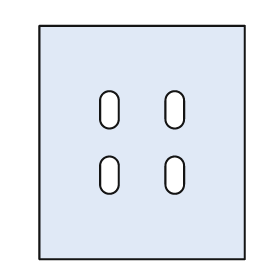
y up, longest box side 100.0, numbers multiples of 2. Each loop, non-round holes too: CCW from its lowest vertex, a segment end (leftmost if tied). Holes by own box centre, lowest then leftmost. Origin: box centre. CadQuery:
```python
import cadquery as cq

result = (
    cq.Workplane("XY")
    .moveTo(-44.0, -50.0)
    .lineTo(44.0, -50.0)
    .lineTo(44.0, 50.0)
    .lineTo(-44.0, 50.0)
    .close()
    .moveTo(-18.0, -18.0)
    .threePointArc((-14.0, -22.0), (-10.0, -18.0))
    .lineTo(-10.0, -10.0)
    .threePointArc((-14.0, -6.0), (-18.0, -10.0))
    .close()
    .moveTo(10.0, -18.0)
    .threePointArc((14.0, -22.0), (18.0, -18.0))
    .lineTo(18.0, -10.0)
    .threePointArc((14.0, -6.0), (10.0, -10.0))
    .close()
    .moveTo(-18.0, 10.0)
    .threePointArc((-14.0, 6.0), (-10.0, 10.0))
    .lineTo(-10.0, 18.0)
    .threePointArc((-14.0, 22.0), (-18.0, 18.0))
    .close()
    .moveTo(10.0, 10.0)
    .threePointArc((14.0, 6.0), (18.0, 10.0))
    .lineTo(18.0, 18.0)
    .threePointArc((14.0, 22.0), (10.0, 18.0))
    .close()
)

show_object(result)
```